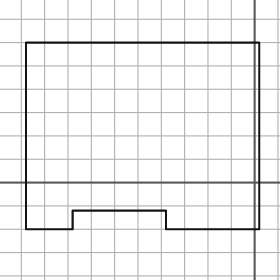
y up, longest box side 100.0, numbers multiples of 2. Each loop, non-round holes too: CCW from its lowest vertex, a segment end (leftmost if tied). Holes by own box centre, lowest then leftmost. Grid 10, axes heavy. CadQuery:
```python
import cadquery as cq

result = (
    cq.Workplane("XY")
    .moveTo(-98.0, -20.0)
    .lineTo(-78.0, -20.0)
    .lineTo(-78.0, -12.0)
    .lineTo(-38.0, -12.0)
    .lineTo(-38.0, -20.0)
    .lineTo(2.0, -20.0)
    .lineTo(2.0, 60.0)
    .lineTo(-98.0, 60.0)
    .close()
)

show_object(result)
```